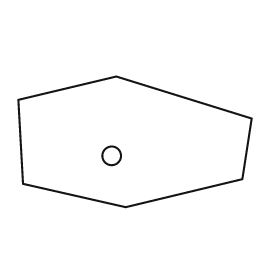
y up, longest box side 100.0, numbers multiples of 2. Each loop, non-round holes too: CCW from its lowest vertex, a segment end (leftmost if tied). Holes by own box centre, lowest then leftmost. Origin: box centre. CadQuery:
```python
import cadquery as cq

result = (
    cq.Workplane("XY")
    .moveTo(-4.0, -28.0)
    .lineTo(46.0, -16.0)
    .lineTo(50.0, 10.0)
    .lineTo(-8.0, 28.0)
    .lineTo(-50.0, 18.0)
    .lineTo(-48.0, -18.0)
    .close()
    .moveTo(-10.0, -6.0)
    .circle(4.0)
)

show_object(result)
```